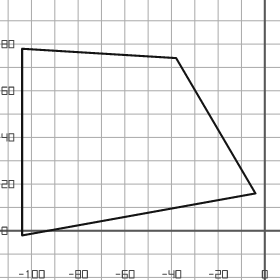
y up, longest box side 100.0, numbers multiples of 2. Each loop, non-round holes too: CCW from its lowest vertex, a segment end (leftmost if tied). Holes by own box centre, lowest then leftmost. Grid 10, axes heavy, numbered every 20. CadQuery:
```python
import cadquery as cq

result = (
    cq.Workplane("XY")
    .moveTo(-104.0, -2.0)
    .lineTo(-4.0, 16.0)
    .lineTo(-38.0, 74.0)
    .lineTo(-104.0, 78.0)
    .close()
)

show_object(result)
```